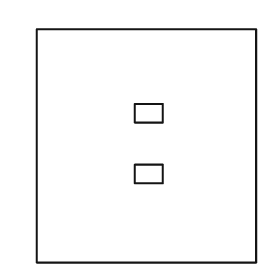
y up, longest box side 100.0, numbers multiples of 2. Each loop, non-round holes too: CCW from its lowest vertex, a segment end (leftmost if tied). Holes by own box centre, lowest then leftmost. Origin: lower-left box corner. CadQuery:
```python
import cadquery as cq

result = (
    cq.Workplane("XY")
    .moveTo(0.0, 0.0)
    .lineTo(94.0, 0.0)
    .lineTo(94.0, 100.0)
    .lineTo(0.0, 100.0)
    .close()
    .moveTo(42.0, 34.0)
    .lineTo(54.0, 34.0)
    .lineTo(54.0, 42.0)
    .lineTo(42.0, 42.0)
    .close()
    .moveTo(42.0, 60.0)
    .lineTo(54.0, 60.0)
    .lineTo(54.0, 68.0)
    .lineTo(42.0, 68.0)
    .close()
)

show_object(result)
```